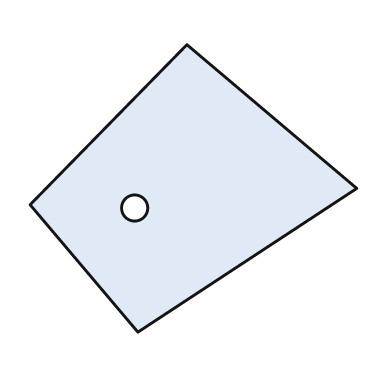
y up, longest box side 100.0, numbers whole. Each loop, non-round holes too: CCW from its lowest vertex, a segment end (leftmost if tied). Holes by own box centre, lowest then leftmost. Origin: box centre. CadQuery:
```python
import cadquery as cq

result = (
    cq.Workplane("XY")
    .moveTo(-17.0, -44.0)
    .lineTo(50.0, 0.0)
    .lineTo(-2.0, 44.0)
    .lineTo(-50.0, -5.0)
    .close()
    .moveTo(-18.0, -6.0)
    .circle(4.0)
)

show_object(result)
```